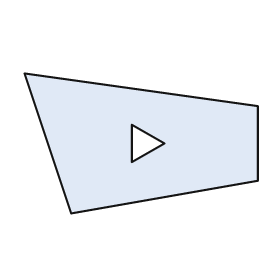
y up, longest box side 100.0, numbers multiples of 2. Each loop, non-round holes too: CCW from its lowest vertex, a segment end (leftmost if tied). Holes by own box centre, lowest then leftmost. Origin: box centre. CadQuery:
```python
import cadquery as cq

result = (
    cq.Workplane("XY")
    .moveTo(-30.0, -30.0)
    .lineTo(50.0, -16.0)
    .lineTo(50.0, 16.0)
    .lineTo(-50.0, 30.0)
    .close()
    .moveTo(-4.0, -8.0)
    .lineTo(10.0, 0.0)
    .lineTo(-4.0, 8.0)
    .close()
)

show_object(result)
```